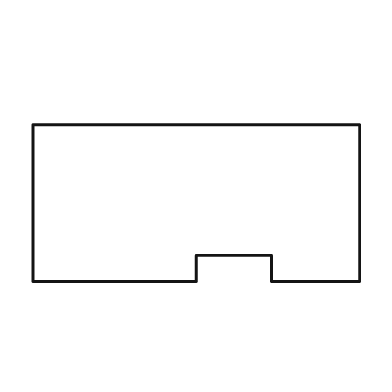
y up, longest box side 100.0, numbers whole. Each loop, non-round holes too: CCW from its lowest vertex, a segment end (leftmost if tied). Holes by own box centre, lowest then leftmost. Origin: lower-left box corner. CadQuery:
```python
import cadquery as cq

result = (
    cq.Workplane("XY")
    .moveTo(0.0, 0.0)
    .lineTo(50.0, 0.0)
    .lineTo(50.0, 8.0)
    .lineTo(73.0, 8.0)
    .lineTo(73.0, 0.0)
    .lineTo(100.0, 0.0)
    .lineTo(100.0, 48.0)
    .lineTo(0.0, 48.0)
    .close()
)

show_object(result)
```